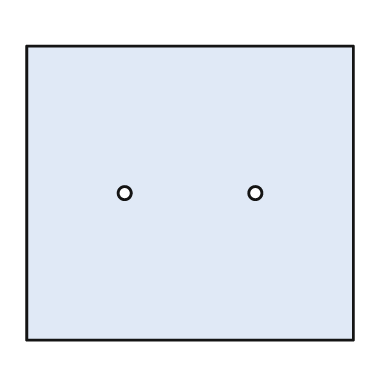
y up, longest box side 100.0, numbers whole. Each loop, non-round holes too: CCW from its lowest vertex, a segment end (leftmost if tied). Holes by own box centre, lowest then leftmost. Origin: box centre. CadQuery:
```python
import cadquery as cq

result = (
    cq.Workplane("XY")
    .moveTo(-50.0, -45.0)
    .lineTo(50.0, -45.0)
    .lineTo(50.0, 45.0)
    .lineTo(-50.0, 45.0)
    .close()
    .moveTo(-20.0, 0.0)
    .circle(2.0)
    .moveTo(20.0, 0.0)
    .circle(2.0)
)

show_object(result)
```